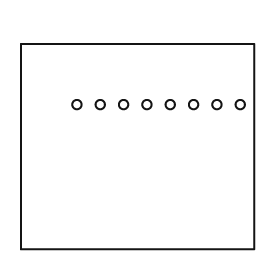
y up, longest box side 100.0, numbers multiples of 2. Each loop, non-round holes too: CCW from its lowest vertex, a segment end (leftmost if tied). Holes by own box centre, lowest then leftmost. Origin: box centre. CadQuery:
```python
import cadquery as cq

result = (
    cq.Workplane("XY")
    .moveTo(-50.0, -44.0)
    .lineTo(50.0, -44.0)
    .lineTo(50.0, 44.0)
    .lineTo(-50.0, 44.0)
    .close()
    .moveTo(-26.0, 18.0)
    .circle(2.0)
    .moveTo(-16.0, 18.0)
    .circle(2.0)
    .moveTo(-6.0, 18.0)
    .circle(2.0)
    .moveTo(4.0, 18.0)
    .circle(2.0)
    .moveTo(14.0, 18.0)
    .circle(2.0)
    .moveTo(24.0, 18.0)
    .circle(2.0)
    .moveTo(34.0, 18.0)
    .circle(2.0)
    .moveTo(44.0, 18.0)
    .circle(2.0)
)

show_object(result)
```